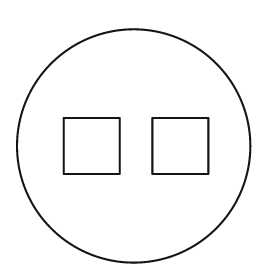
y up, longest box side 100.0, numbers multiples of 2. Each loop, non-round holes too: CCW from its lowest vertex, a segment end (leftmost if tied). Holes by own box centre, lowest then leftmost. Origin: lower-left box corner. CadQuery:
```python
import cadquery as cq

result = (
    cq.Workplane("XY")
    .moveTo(50.0, 50.0)
    .circle(50.0)
    .moveTo(20.0, 38.0)
    .lineTo(44.0, 38.0)
    .lineTo(44.0, 62.0)
    .lineTo(20.0, 62.0)
    .close()
    .moveTo(58.0, 38.0)
    .lineTo(82.0, 38.0)
    .lineTo(82.0, 62.0)
    .lineTo(58.0, 62.0)
    .close()
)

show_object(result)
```